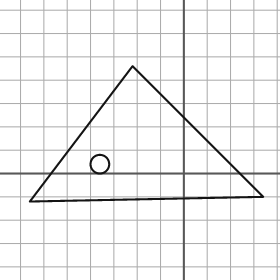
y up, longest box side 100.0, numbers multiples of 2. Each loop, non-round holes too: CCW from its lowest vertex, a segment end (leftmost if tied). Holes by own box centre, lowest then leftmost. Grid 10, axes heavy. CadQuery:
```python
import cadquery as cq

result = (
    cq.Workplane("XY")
    .moveTo(-66.0, -12.0)
    .lineTo(34.0, -10.0)
    .lineTo(-22.0, 46.0)
    .close()
    .moveTo(-36.0, 4.0)
    .circle(4.0)
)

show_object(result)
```